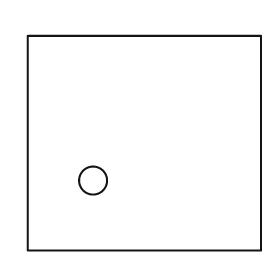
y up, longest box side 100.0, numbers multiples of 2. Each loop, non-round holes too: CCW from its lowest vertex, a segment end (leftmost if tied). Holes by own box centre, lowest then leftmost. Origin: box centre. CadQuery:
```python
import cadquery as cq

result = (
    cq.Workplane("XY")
    .moveTo(-50.0, -46.0)
    .lineTo(50.0, -46.0)
    .lineTo(50.0, 46.0)
    .lineTo(-50.0, 46.0)
    .close()
    .moveTo(-22.0, -16.0)
    .circle(6.0)
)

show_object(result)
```